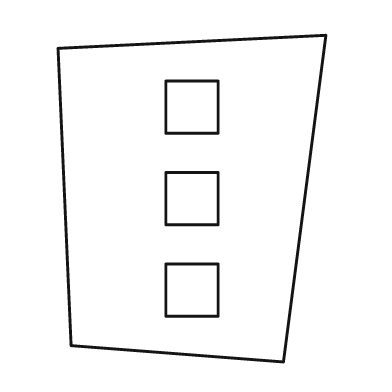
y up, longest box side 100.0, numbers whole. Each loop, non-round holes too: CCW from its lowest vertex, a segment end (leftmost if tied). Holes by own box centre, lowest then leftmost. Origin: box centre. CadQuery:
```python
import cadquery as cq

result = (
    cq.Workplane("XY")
    .moveTo(28.0, -50.0)
    .lineTo(41.0, 50.0)
    .lineTo(-41.0, 46.0)
    .lineTo(-37.0, -45.0)
    .close()
    .moveTo(-8.0, -36.0)
    .lineTo(8.0, -36.0)
    .lineTo(8.0, -20.0)
    .lineTo(-8.0, -20.0)
    .close()
    .moveTo(-8.0, -8.0)
    .lineTo(8.0, -8.0)
    .lineTo(8.0, 8.0)
    .lineTo(-8.0, 8.0)
    .close()
    .moveTo(-8.0, 20.0)
    .lineTo(8.0, 20.0)
    .lineTo(8.0, 36.0)
    .lineTo(-8.0, 36.0)
    .close()
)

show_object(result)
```